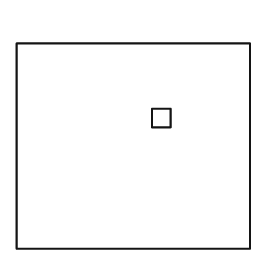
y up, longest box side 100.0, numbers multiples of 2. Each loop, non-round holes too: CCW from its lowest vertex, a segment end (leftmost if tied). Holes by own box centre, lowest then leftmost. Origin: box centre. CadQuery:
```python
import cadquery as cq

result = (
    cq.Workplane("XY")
    .moveTo(-50.0, -44.0)
    .lineTo(50.0, -44.0)
    .lineTo(50.0, 44.0)
    .lineTo(-50.0, 44.0)
    .close()
    .moveTo(8.0, 8.0)
    .lineTo(16.0, 8.0)
    .lineTo(16.0, 16.0)
    .lineTo(8.0, 16.0)
    .close()
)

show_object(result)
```